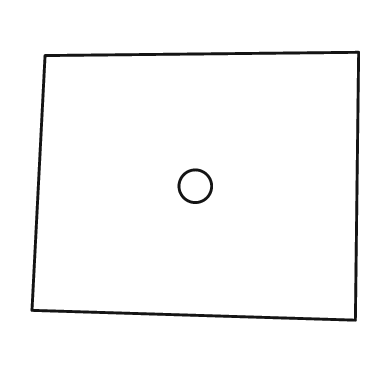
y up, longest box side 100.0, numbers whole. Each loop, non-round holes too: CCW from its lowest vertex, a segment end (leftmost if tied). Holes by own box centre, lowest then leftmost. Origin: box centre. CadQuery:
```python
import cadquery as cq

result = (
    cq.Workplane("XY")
    .moveTo(49.0, -41.0)
    .lineTo(50.0, 41.0)
    .lineTo(-46.0, 40.0)
    .lineTo(-50.0, -38.0)
    .close()
    .moveTo(0.0, 0.0)
    .circle(5.0)
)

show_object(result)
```